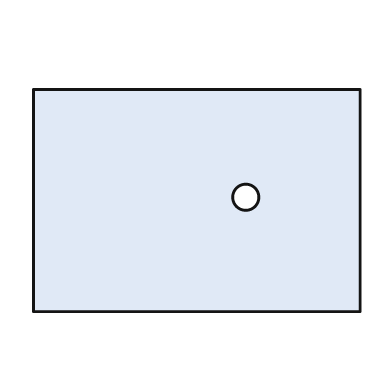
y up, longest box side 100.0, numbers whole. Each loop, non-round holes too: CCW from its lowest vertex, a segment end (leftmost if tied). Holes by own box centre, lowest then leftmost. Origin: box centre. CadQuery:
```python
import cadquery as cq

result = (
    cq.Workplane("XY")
    .moveTo(-50.0, -34.0)
    .lineTo(50.0, -34.0)
    .lineTo(50.0, 34.0)
    .lineTo(-50.0, 34.0)
    .close()
    .moveTo(15.0, 1.0)
    .circle(4.0)
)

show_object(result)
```